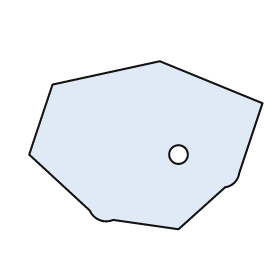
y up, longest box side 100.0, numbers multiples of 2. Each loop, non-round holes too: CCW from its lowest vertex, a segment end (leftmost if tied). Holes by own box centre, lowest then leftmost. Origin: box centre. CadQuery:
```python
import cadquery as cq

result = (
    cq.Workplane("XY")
    .moveTo(14.0, -36.0)
    .lineTo(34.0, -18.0)
    .threePointArc((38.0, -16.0), (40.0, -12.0))
    .lineTo(50.0, 18.0)
    .lineTo(6.0, 36.0)
    .lineTo(-40.0, 26.0)
    .lineTo(-50.0, -4.0)
    .lineTo(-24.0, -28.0)
    .threePointArc((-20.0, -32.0), (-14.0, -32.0))
    .close()
    .moveTo(14.0, -4.0)
    .circle(4.0)
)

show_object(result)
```